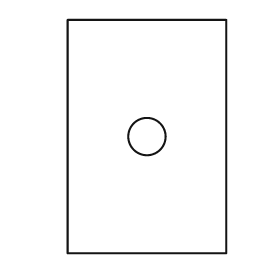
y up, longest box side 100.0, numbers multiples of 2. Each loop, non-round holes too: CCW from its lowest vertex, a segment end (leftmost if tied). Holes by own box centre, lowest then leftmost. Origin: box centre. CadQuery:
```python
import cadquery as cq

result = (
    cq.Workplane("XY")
    .moveTo(-34.0, -50.0)
    .lineTo(34.0, -50.0)
    .lineTo(34.0, 50.0)
    .lineTo(-34.0, 50.0)
    .close()
    .moveTo(0.0, 0.0)
    .circle(8.0)
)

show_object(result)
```